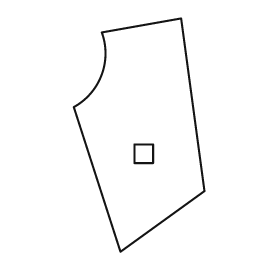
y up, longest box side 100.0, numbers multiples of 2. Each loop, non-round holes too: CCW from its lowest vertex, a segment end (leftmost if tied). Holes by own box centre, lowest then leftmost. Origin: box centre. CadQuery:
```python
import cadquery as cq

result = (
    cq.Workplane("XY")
    .moveTo(-8.0, -50.0)
    .lineTo(28.0, -24.0)
    .lineTo(18.0, 50.0)
    .lineTo(-16.0, 44.0)
    .threePointArc((-16.0, 26.0), (-28.0, 12.0))
    .close()
    .moveTo(-2.0, -12.0)
    .lineTo(6.0, -12.0)
    .lineTo(6.0, -4.0)
    .lineTo(-2.0, -4.0)
    .close()
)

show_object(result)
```